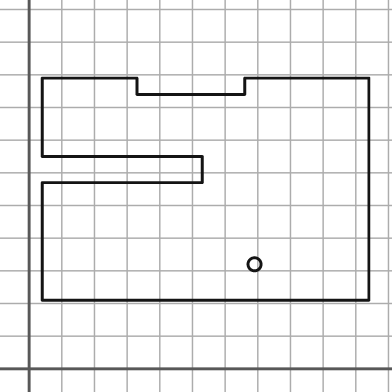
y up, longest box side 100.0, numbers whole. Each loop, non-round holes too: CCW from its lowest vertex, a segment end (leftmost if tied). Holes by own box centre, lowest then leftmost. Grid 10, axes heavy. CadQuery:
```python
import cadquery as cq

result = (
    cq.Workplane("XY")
    .moveTo(4.0, 21.0)
    .lineTo(104.0, 21.0)
    .lineTo(104.0, 89.0)
    .lineTo(66.0, 89.0)
    .lineTo(66.0, 84.0)
    .lineTo(33.0, 84.0)
    .lineTo(33.0, 89.0)
    .lineTo(4.0, 89.0)
    .lineTo(4.0, 65.0)
    .lineTo(53.0, 65.0)
    .lineTo(53.0, 57.0)
    .lineTo(4.0, 57.0)
    .close()
    .moveTo(69.0, 32.0)
    .circle(2.0)
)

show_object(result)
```